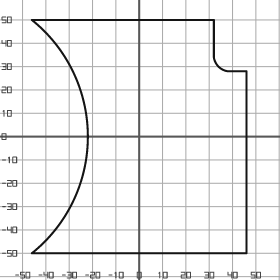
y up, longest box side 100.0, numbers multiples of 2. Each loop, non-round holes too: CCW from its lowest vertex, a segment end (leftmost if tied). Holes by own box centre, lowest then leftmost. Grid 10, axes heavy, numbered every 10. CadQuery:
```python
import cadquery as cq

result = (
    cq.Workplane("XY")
    .moveTo(-46.0, -50.0)
    .lineTo(46.0, -50.0)
    .lineTo(46.0, 28.0)
    .lineTo(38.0, 28.0)
    .threePointArc((34.0, 30.0), (32.0, 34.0))
    .lineTo(32.0, 50.0)
    .lineTo(-46.0, 50.0)
    .threePointArc((-22.0, 0.0), (-46.0, -50.0))
    .close()
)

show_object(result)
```